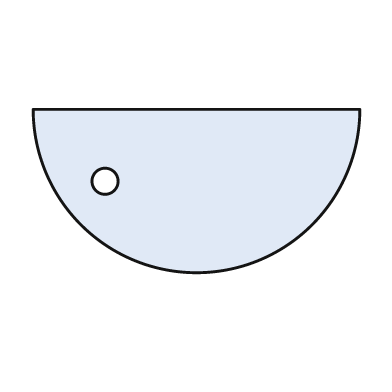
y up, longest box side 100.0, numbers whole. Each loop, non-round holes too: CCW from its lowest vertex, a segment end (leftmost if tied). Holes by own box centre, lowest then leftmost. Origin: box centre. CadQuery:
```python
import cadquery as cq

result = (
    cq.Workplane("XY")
    .moveTo(-50.0, 25.0)
    .threePointArc((0.0, -25.0), (50.0, 25.0))
    .close()
    .moveTo(-28.0, 3.0)
    .circle(4.0)
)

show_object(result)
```